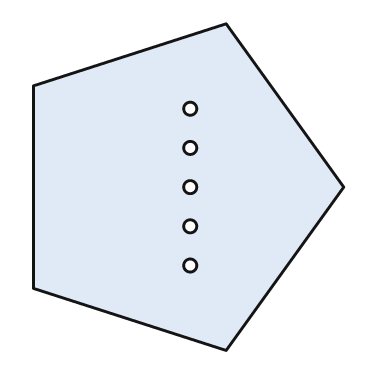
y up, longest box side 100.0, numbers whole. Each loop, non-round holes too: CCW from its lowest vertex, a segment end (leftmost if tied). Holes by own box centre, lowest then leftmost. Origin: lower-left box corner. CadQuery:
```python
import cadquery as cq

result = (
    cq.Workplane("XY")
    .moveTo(59.0, 0.0)
    .lineTo(95.0, 50.0)
    .lineTo(59.0, 100.0)
    .lineTo(0.0, 81.0)
    .lineTo(0.0, 19.0)
    .close()
    .moveTo(48.0, 26.0)
    .circle(2.0)
    .moveTo(48.0, 38.0)
    .circle(2.0)
    .moveTo(48.0, 50.0)
    .circle(2.0)
    .moveTo(48.0, 62.0)
    .circle(2.0)
    .moveTo(48.0, 74.0)
    .circle(2.0)
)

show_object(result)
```